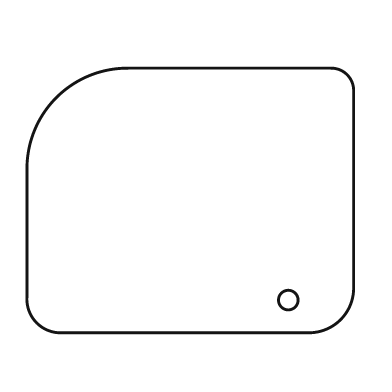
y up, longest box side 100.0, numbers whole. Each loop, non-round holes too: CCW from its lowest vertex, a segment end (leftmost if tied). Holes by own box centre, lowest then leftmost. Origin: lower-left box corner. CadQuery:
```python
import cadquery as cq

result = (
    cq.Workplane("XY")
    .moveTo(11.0, 0.0)
    .lineTo(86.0, 0.0)
    .threePointArc((96.0, 4.0), (100.0, 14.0))
    .lineTo(100.0, 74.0)
    .threePointArc((98.0, 79.0), (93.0, 81.0))
    .lineTo(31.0, 81.0)
    .threePointArc((9.0, 72.0), (0.0, 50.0))
    .lineTo(0.0, 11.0)
    .threePointArc((3.0, 3.0), (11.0, 0.0))
    .close()
    .moveTo(80.0, 10.0)
    .circle(3.0)
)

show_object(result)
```